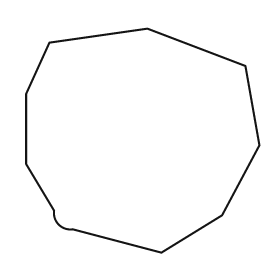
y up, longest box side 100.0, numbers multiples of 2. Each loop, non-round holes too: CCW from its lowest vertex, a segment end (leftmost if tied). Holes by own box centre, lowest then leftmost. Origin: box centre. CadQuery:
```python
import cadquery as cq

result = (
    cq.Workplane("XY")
    .moveTo(8.0, -48.0)
    .lineTo(34.0, -32.0)
    .lineTo(50.0, -2.0)
    .lineTo(44.0, 32.0)
    .lineTo(2.0, 48.0)
    .lineTo(-40.0, 42.0)
    .lineTo(-50.0, 20.0)
    .lineTo(-50.0, -10.0)
    .lineTo(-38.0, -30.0)
    .threePointArc((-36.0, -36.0), (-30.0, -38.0))
    .close()
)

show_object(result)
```